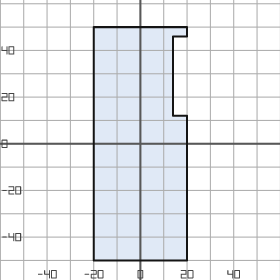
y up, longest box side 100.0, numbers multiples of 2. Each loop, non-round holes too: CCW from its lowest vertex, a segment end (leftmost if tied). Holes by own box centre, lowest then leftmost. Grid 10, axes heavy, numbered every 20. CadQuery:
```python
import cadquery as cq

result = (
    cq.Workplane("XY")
    .moveTo(-20.0, -50.0)
    .lineTo(20.0, -50.0)
    .lineTo(20.0, 12.0)
    .lineTo(14.0, 12.0)
    .lineTo(14.0, 46.0)
    .lineTo(20.0, 46.0)
    .lineTo(20.0, 50.0)
    .lineTo(-20.0, 50.0)
    .close()
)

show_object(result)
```